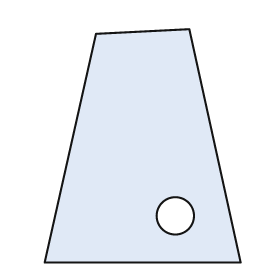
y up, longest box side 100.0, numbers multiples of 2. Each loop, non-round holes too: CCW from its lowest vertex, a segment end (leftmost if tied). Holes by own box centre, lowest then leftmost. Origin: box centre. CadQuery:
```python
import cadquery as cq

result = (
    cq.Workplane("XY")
    .moveTo(-42.0, -50.0)
    .lineTo(42.0, -50.0)
    .lineTo(20.0, 50.0)
    .lineTo(-20.0, 48.0)
    .close()
    .moveTo(14.0, -30.0)
    .circle(8.0)
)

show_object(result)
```